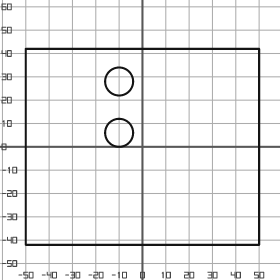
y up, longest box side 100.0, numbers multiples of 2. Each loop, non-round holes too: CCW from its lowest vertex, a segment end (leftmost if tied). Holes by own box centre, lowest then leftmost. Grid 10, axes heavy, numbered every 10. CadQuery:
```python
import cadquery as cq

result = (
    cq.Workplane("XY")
    .moveTo(-50.0, -42.0)
    .lineTo(50.0, -42.0)
    .lineTo(50.0, 42.0)
    .lineTo(-50.0, 42.0)
    .close()
    .moveTo(-10.0, 6.0)
    .circle(6.0)
    .moveTo(-10.0, 28.0)
    .circle(6.0)
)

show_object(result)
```